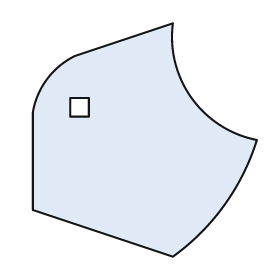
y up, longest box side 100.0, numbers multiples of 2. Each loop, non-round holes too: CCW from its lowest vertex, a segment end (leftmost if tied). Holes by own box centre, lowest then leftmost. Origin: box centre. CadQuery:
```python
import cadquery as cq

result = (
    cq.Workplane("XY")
    .moveTo(12.0, -50.0)
    .threePointArc((34.0, -28.0), (48.0, 0.0))
    .threePointArc((20.0, 18.0), (12.0, 50.0))
    .lineTo(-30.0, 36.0)
    .threePointArc((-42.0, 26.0), (-48.0, 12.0))
    .lineTo(-48.0, -30.0)
    .close()
    .moveTo(-32.0, 10.0)
    .lineTo(-24.0, 10.0)
    .lineTo(-24.0, 18.0)
    .lineTo(-32.0, 18.0)
    .close()
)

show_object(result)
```